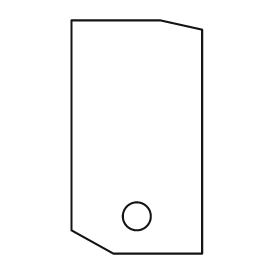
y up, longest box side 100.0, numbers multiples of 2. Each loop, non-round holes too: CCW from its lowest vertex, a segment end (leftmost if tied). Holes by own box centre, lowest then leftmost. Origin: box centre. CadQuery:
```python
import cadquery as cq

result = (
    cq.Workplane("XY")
    .moveTo(-10.0, -50.0)
    .lineTo(28.0, -50.0)
    .lineTo(28.0, 46.0)
    .lineTo(10.0, 50.0)
    .lineTo(-28.0, 50.0)
    .lineTo(-28.0, -40.0)
    .close()
    .moveTo(0.0, -34.0)
    .circle(6.0)
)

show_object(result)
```